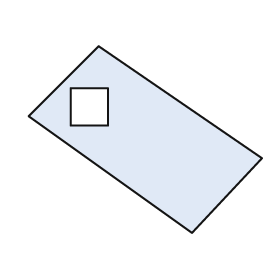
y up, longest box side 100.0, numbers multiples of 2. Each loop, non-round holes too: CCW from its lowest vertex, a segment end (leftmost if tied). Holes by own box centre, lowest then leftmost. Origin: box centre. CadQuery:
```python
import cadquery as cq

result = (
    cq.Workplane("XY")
    .moveTo(20.0, -40.0)
    .lineTo(50.0, -8.0)
    .lineTo(-20.0, 40.0)
    .lineTo(-50.0, 10.0)
    .close()
    .moveTo(-32.0, 6.0)
    .lineTo(-16.0, 6.0)
    .lineTo(-16.0, 22.0)
    .lineTo(-32.0, 22.0)
    .close()
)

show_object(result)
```